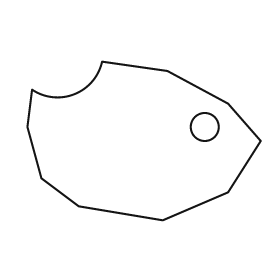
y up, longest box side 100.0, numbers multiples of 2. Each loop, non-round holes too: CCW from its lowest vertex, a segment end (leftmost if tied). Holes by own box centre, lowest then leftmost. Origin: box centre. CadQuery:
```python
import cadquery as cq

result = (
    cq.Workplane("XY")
    .moveTo(8.0, -34.0)
    .lineTo(36.0, -22.0)
    .lineTo(50.0, 0.0)
    .lineTo(36.0, 16.0)
    .lineTo(10.0, 30.0)
    .lineTo(-18.0, 34.0)
    .threePointArc((-30.0, 20.0), (-48.0, 22.0))
    .lineTo(-50.0, 6.0)
    .lineTo(-44.0, -16.0)
    .lineTo(-28.0, -28.0)
    .close()
    .moveTo(26.0, 6.0)
    .circle(6.0)
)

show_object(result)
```